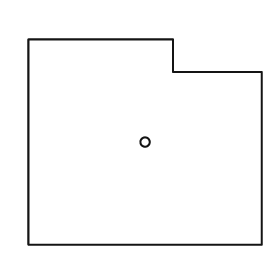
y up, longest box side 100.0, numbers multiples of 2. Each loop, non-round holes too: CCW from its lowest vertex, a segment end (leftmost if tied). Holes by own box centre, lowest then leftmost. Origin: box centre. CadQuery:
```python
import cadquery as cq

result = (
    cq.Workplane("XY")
    .moveTo(-50.0, -44.0)
    .lineTo(50.0, -44.0)
    .lineTo(50.0, 30.0)
    .lineTo(12.0, 30.0)
    .lineTo(12.0, 44.0)
    .lineTo(-50.0, 44.0)
    .close()
    .moveTo(0.0, 0.0)
    .circle(2.0)
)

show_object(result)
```